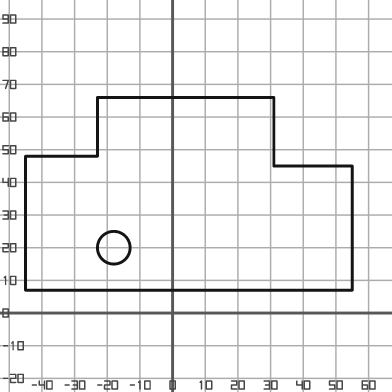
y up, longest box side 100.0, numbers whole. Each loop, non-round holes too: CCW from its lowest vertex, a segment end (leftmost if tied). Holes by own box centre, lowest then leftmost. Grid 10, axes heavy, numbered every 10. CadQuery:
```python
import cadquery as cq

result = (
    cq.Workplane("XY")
    .moveTo(-45.0, 7.0)
    .lineTo(55.0, 7.0)
    .lineTo(55.0, 45.0)
    .lineTo(31.0, 45.0)
    .lineTo(31.0, 66.0)
    .lineTo(-23.0, 66.0)
    .lineTo(-23.0, 48.0)
    .lineTo(-45.0, 48.0)
    .close()
    .moveTo(-18.0, 20.0)
    .circle(5.0)
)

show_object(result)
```